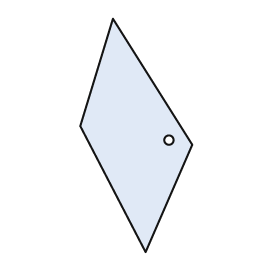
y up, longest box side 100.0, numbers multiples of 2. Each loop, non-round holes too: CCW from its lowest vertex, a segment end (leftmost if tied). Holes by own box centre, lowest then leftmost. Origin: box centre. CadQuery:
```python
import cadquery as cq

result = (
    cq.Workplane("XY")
    .moveTo(4.0, -50.0)
    .lineTo(24.0, -4.0)
    .lineTo(-10.0, 50.0)
    .lineTo(-24.0, 4.0)
    .close()
    .moveTo(14.0, -2.0)
    .circle(2.0)
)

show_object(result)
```